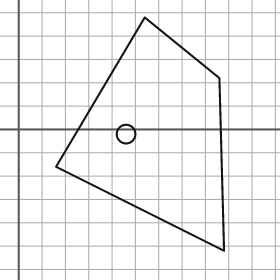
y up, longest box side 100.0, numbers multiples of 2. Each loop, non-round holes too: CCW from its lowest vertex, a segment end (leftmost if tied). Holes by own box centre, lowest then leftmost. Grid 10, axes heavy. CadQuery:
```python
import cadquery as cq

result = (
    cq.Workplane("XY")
    .moveTo(88.0, -52.0)
    .lineTo(86.0, 22.0)
    .lineTo(54.0, 48.0)
    .lineTo(16.0, -16.0)
    .close()
    .moveTo(46.0, -2.0)
    .circle(4.0)
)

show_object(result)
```